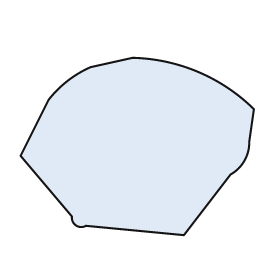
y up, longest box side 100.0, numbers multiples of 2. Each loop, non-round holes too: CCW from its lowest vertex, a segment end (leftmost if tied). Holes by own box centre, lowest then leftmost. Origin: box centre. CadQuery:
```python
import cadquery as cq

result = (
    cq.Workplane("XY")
    .moveTo(20.0, -38.0)
    .lineTo(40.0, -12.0)
    .threePointArc((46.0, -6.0), (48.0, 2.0))
    .lineTo(50.0, 16.0)
    .threePointArc((26.0, 32.0), (-2.0, 38.0))
    .lineTo(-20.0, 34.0)
    .threePointArc((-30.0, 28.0), (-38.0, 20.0))
    .lineTo(-50.0, -4.0)
    .lineTo(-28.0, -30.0)
    .threePointArc((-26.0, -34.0), (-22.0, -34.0))
    .close()
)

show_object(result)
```